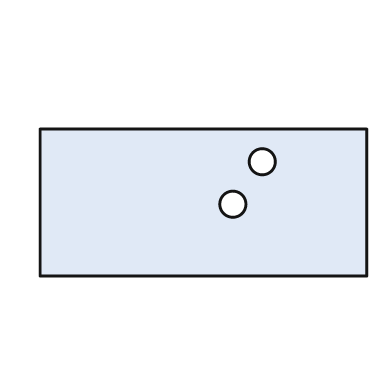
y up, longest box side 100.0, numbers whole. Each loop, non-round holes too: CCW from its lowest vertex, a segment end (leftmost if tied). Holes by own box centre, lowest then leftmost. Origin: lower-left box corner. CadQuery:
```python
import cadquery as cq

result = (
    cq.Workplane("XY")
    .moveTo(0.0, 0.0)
    .lineTo(100.0, 0.0)
    .lineTo(100.0, 45.0)
    .lineTo(0.0, 45.0)
    .close()
    .moveTo(59.0, 22.0)
    .circle(4.0)
    .moveTo(68.0, 35.0)
    .circle(4.0)
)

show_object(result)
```